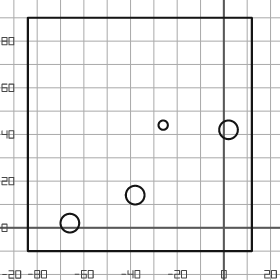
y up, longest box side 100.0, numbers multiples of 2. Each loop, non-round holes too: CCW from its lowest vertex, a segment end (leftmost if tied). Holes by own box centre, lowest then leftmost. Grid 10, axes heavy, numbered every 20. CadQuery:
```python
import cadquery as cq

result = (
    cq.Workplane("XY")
    .moveTo(-84.0, -10.0)
    .lineTo(12.0, -10.0)
    .lineTo(12.0, 90.0)
    .lineTo(-84.0, 90.0)
    .close()
    .moveTo(-66.0, 2.0)
    .circle(4.0)
    .moveTo(-38.0, 14.0)
    .circle(4.0)
    .moveTo(2.0, 42.0)
    .circle(4.0)
    .moveTo(-26.0, 44.0)
    .circle(2.0)
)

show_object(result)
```